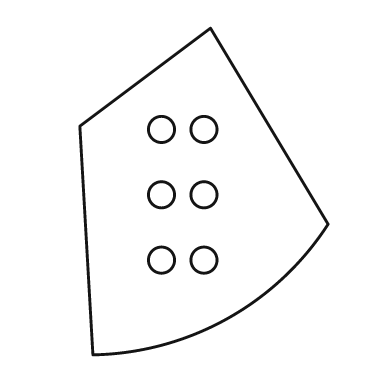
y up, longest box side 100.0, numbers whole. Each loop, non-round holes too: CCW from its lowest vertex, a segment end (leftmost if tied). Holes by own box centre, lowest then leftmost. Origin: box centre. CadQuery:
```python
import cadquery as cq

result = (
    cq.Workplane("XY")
    .moveTo(-34.0, -50.0)
    .threePointArc((7.0, -39.0), (38.0, -10.0))
    .lineTo(2.0, 50.0)
    .lineTo(-38.0, 20.0)
    .close()
    .moveTo(-13.0, -21.0)
    .circle(4.0)
    .moveTo(0.0, -21.0)
    .circle(4.0)
    .moveTo(-13.0, -1.0)
    .circle(4.0)
    .moveTo(0.0, -1.0)
    .circle(4.0)
    .moveTo(-13.0, 19.0)
    .circle(4.0)
    .moveTo(0.0, 19.0)
    .circle(4.0)
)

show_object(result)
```